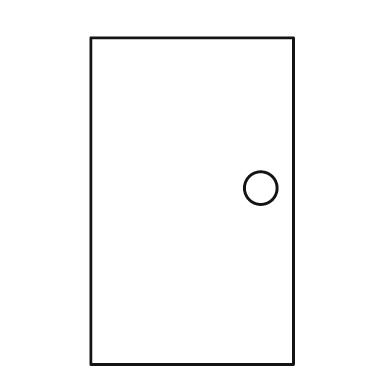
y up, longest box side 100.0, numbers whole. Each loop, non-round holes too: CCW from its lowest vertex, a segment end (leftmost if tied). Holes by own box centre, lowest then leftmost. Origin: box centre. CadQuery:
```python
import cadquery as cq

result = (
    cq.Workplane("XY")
    .moveTo(-31.0, -50.0)
    .lineTo(31.0, -50.0)
    .lineTo(31.0, 50.0)
    .lineTo(-31.0, 50.0)
    .close()
    .moveTo(21.0, 4.0)
    .circle(5.0)
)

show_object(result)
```